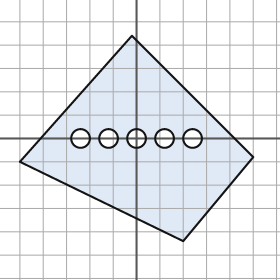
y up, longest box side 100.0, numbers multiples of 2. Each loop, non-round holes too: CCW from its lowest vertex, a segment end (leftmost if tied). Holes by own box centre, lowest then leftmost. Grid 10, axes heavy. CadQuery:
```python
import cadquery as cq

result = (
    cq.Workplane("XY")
    .moveTo(20.0, -44.0)
    .lineTo(50.0, -8.0)
    .lineTo(-2.0, 44.0)
    .lineTo(-50.0, -10.0)
    .close()
    .moveTo(-24.0, 0.0)
    .circle(4.0)
    .moveTo(-12.0, 0.0)
    .circle(4.0)
    .moveTo(0.0, 0.0)
    .circle(4.0)
    .moveTo(12.0, 0.0)
    .circle(4.0)
    .moveTo(24.0, 0.0)
    .circle(4.0)
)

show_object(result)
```